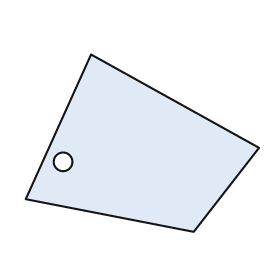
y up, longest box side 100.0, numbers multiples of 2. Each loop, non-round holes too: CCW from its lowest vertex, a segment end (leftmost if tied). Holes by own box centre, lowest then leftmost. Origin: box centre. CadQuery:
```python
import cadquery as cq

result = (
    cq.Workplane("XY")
    .moveTo(22.0, -38.0)
    .lineTo(50.0, -2.0)
    .lineTo(-22.0, 38.0)
    .lineTo(-50.0, -24.0)
    .close()
    .moveTo(-34.0, -8.0)
    .circle(4.0)
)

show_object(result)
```